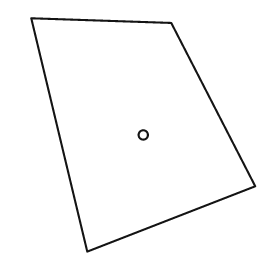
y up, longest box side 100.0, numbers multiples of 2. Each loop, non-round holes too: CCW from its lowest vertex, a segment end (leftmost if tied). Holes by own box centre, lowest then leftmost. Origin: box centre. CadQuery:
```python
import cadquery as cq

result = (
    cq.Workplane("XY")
    .moveTo(-24.0, -50.0)
    .lineTo(48.0, -22.0)
    .lineTo(12.0, 48.0)
    .lineTo(-48.0, 50.0)
    .close()
    .moveTo(0.0, 0.0)
    .circle(2.0)
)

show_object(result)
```